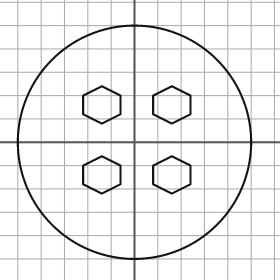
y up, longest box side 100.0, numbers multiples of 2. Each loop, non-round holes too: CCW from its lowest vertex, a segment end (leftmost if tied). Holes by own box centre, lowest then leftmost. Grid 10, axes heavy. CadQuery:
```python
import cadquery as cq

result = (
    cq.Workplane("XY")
    .moveTo(0.0, 0.0)
    .circle(50.0)
    .moveTo(-14.0, -22.0)
    .lineTo(-6.0, -18.0)
    .lineTo(-6.0, -10.0)
    .lineTo(-14.0, -6.0)
    .lineTo(-22.0, -10.0)
    .lineTo(-22.0, -18.0)
    .close()
    .moveTo(16.0, -22.0)
    .lineTo(24.0, -18.0)
    .lineTo(24.0, -10.0)
    .lineTo(16.0, -6.0)
    .lineTo(8.0, -10.0)
    .lineTo(8.0, -18.0)
    .close()
    .moveTo(-14.0, 8.0)
    .lineTo(-6.0, 12.0)
    .lineTo(-6.0, 20.0)
    .lineTo(-14.0, 24.0)
    .lineTo(-22.0, 20.0)
    .lineTo(-22.0, 12.0)
    .close()
    .moveTo(16.0, 8.0)
    .lineTo(24.0, 12.0)
    .lineTo(24.0, 20.0)
    .lineTo(16.0, 24.0)
    .lineTo(8.0, 20.0)
    .lineTo(8.0, 12.0)
    .close()
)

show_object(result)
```